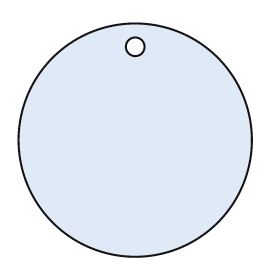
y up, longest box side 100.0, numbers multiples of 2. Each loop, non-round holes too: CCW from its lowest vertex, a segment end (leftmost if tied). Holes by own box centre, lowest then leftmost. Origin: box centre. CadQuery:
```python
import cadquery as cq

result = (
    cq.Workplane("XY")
    .moveTo(0.0, 0.0)
    .circle(50.0)
    .moveTo(0.0, 40.0)
    .circle(4.0)
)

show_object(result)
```